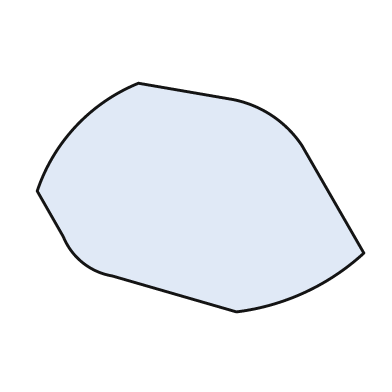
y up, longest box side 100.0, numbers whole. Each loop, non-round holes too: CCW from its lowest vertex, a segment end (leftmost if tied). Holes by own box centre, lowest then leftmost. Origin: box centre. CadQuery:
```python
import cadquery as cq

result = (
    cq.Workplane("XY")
    .moveTo(11.0, -35.0)
    .threePointArc((32.0, -29.0), (50.0, -17.0))
    .lineTo(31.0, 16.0)
    .threePointArc((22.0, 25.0), (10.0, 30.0))
    .lineTo(-19.0, 35.0)
    .threePointArc((-38.0, 22.0), (-50.0, 2.0))
    .lineTo(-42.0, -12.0)
    .threePointArc((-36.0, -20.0), (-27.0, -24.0))
    .close()
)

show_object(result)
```